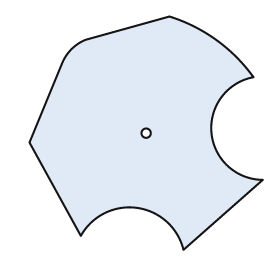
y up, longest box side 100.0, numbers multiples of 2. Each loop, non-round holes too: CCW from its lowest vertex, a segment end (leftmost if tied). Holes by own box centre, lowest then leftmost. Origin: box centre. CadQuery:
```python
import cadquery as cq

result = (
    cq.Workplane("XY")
    .moveTo(16.0, -50.0)
    .lineTo(50.0, -20.0)
    .threePointArc((28.0, 0.0), (46.0, 24.0))
    .threePointArc((30.0, 40.0), (10.0, 50.0))
    .lineTo(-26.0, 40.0)
    .threePointArc((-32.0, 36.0), (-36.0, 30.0))
    .lineTo(-50.0, -4.0)
    .lineTo(-28.0, -44.0)
    .threePointArc((-4.0, -32.0), (16.0, -50.0))
    .close()
    .moveTo(0.0, 0.0)
    .circle(2.0)
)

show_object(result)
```